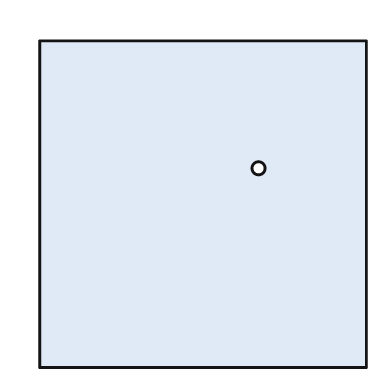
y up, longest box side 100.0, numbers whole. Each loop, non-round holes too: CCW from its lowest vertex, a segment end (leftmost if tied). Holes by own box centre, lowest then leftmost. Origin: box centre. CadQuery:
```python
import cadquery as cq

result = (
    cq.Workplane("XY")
    .moveTo(-50.0, -50.0)
    .lineTo(50.0, -50.0)
    .lineTo(50.0, 50.0)
    .lineTo(-50.0, 50.0)
    .close()
    .moveTo(17.0, 11.0)
    .circle(2.0)
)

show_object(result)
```